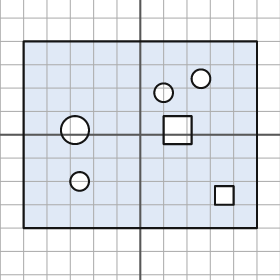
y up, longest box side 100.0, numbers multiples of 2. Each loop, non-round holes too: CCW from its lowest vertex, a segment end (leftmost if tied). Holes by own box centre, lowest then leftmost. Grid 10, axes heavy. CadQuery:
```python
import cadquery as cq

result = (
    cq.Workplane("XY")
    .moveTo(-50.0, -40.0)
    .lineTo(50.0, -40.0)
    .lineTo(50.0, 40.0)
    .lineTo(-50.0, 40.0)
    .close()
    .moveTo(32.0, -30.0)
    .lineTo(40.0, -30.0)
    .lineTo(40.0, -22.0)
    .lineTo(32.0, -22.0)
    .close()
    .moveTo(-26.0, -20.0)
    .circle(4.0)
    .moveTo(-28.0, 2.0)
    .circle(6.0)
    .moveTo(10.0, -4.0)
    .lineTo(22.0, -4.0)
    .lineTo(22.0, 8.0)
    .lineTo(10.0, 8.0)
    .close()
    .moveTo(10.0, 18.0)
    .circle(4.0)
    .moveTo(26.0, 24.0)
    .circle(4.0)
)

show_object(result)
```